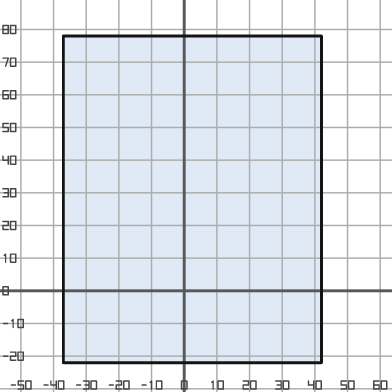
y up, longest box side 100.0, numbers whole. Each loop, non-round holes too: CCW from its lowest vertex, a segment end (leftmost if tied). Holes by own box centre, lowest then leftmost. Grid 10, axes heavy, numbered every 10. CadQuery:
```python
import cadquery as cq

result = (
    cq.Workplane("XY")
    .moveTo(-37.0, -22.0)
    .lineTo(42.0, -22.0)
    .lineTo(42.0, 78.0)
    .lineTo(-37.0, 78.0)
    .close()
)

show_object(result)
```